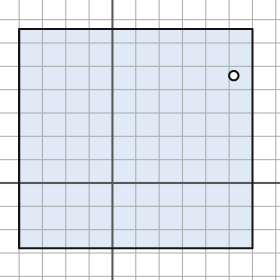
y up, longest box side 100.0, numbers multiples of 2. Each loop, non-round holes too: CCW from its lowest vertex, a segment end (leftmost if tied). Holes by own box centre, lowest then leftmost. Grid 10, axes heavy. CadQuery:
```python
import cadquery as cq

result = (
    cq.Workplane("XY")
    .moveTo(-40.0, -28.0)
    .lineTo(60.0, -28.0)
    .lineTo(60.0, 66.0)
    .lineTo(-40.0, 66.0)
    .close()
    .moveTo(52.0, 46.0)
    .circle(2.0)
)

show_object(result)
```